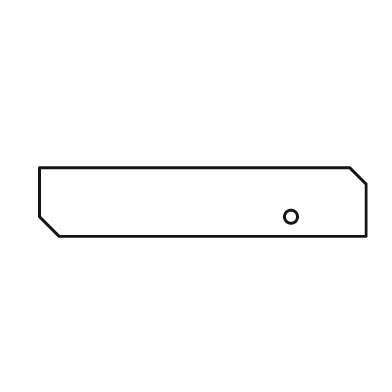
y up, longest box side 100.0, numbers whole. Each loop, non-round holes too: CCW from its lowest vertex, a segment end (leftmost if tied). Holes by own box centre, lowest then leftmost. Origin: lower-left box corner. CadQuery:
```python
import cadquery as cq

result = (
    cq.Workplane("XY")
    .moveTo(6.0, 0.0)
    .lineTo(100.0, 0.0)
    .lineTo(100.0, 16.0)
    .lineTo(95.0, 21.0)
    .lineTo(0.0, 21.0)
    .lineTo(0.0, 6.0)
    .close()
    .moveTo(77.0, 6.0)
    .circle(2.0)
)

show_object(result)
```